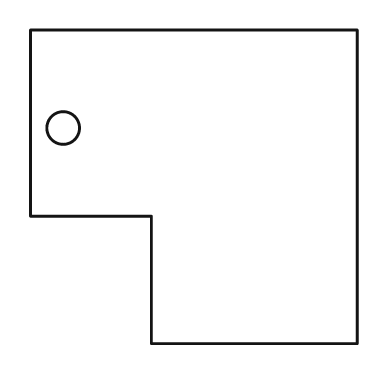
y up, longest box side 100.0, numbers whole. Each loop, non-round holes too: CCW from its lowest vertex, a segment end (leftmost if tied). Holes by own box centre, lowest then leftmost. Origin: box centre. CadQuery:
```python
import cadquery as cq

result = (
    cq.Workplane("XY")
    .moveTo(-13.0, -48.0)
    .lineTo(50.0, -48.0)
    .lineTo(50.0, 48.0)
    .lineTo(-50.0, 48.0)
    .lineTo(-50.0, -9.0)
    .lineTo(-13.0, -9.0)
    .close()
    .moveTo(-40.0, 18.0)
    .circle(5.0)
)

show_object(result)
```